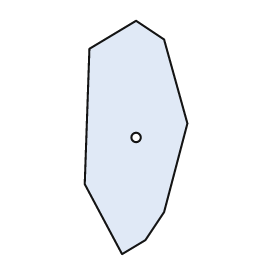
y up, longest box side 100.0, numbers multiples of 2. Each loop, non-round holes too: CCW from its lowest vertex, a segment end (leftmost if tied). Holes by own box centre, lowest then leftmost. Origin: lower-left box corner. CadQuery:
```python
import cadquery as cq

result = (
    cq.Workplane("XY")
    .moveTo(16.0, 0.0)
    .lineTo(26.0, 6.0)
    .lineTo(34.0, 18.0)
    .lineTo(44.0, 56.0)
    .lineTo(34.0, 92.0)
    .lineTo(22.0, 100.0)
    .lineTo(2.0, 88.0)
    .lineTo(0.0, 30.0)
    .close()
    .moveTo(22.0, 50.0)
    .circle(2.0)
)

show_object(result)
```